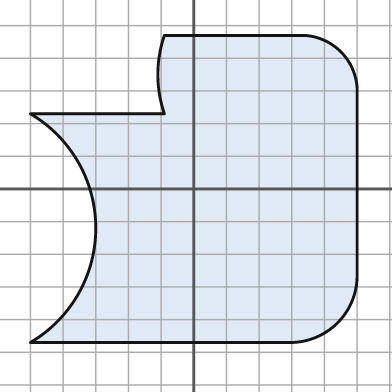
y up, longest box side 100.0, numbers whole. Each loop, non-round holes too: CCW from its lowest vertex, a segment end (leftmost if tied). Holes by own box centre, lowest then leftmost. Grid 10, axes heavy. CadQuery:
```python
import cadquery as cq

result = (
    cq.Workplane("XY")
    .moveTo(-50.0, -47.0)
    .lineTo(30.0, -47.0)
    .threePointArc((44.0, -41.0), (50.0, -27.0))
    .lineTo(50.0, 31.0)
    .threePointArc((45.0, 42.0), (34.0, 47.0))
    .lineTo(-9.0, 47.0)
    .threePointArc((-11.0, 35.0), (-9.0, 23.0))
    .lineTo(-50.0, 23.0)
    .threePointArc((-30.0, -12.0), (-50.0, -47.0))
    .close()
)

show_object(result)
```